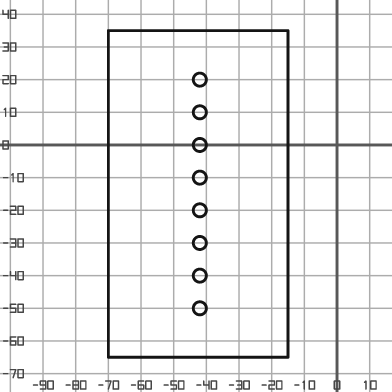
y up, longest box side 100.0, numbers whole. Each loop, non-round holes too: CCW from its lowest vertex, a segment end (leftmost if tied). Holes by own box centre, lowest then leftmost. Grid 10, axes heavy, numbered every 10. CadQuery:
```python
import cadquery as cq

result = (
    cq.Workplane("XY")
    .moveTo(-70.0, -65.0)
    .lineTo(-15.0, -65.0)
    .lineTo(-15.0, 35.0)
    .lineTo(-70.0, 35.0)
    .close()
    .moveTo(-42.0, -50.0)
    .circle(2.0)
    .moveTo(-42.0, -40.0)
    .circle(2.0)
    .moveTo(-42.0, -30.0)
    .circle(2.0)
    .moveTo(-42.0, -20.0)
    .circle(2.0)
    .moveTo(-42.0, -10.0)
    .circle(2.0)
    .moveTo(-42.0, 0.0)
    .circle(2.0)
    .moveTo(-42.0, 10.0)
    .circle(2.0)
    .moveTo(-42.0, 20.0)
    .circle(2.0)
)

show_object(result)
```